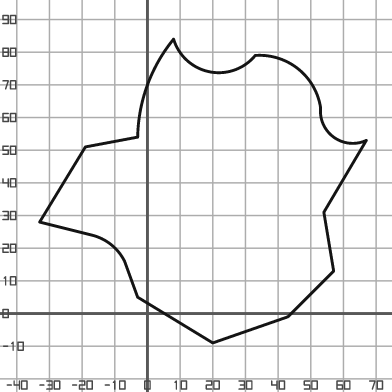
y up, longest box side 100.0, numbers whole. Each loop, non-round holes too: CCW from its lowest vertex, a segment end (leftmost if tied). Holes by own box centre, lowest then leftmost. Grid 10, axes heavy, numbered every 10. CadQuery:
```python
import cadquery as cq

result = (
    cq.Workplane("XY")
    .moveTo(20.0, -9.0)
    .lineTo(43.0, -1.0)
    .lineTo(57.0, 13.0)
    .lineTo(54.0, 31.0)
    .lineTo(67.0, 53.0)
    .threePointArc((57.0, 54.0), (53.0, 63.0))
    .threePointArc((46.0, 75.0), (33.0, 79.0))
    .threePointArc((19.0, 74.0), (8.0, 84.0))
    .threePointArc((0.0, 70.0), (-3.0, 54.0))
    .lineTo(-19.0, 51.0)
    .lineTo(-33.0, 28.0)
    .lineTo(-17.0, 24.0)
    .threePointArc((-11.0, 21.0), (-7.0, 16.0))
    .lineTo(-3.0, 5.0)
    .close()
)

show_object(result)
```